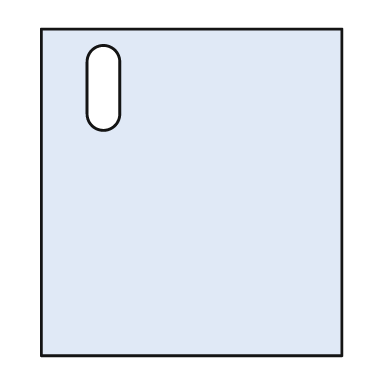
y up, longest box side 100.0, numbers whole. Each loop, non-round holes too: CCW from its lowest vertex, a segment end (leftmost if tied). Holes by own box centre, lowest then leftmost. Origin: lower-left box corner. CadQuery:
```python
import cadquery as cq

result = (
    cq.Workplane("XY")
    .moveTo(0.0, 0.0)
    .lineTo(92.0, 0.0)
    .lineTo(92.0, 100.0)
    .lineTo(0.0, 100.0)
    .close()
    .moveTo(14.0, 74.0)
    .threePointArc((19.0, 69.0), (24.0, 74.0))
    .lineTo(24.0, 90.0)
    .threePointArc((19.0, 95.0), (14.0, 90.0))
    .close()
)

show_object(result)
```